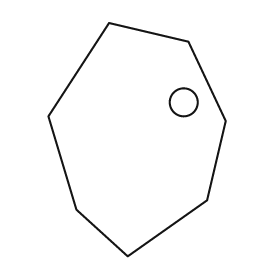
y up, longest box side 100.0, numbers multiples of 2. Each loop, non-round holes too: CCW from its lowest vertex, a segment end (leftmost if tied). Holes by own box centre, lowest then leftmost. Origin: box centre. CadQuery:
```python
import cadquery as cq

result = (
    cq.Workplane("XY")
    .moveTo(-4.0, -50.0)
    .lineTo(30.0, -26.0)
    .lineTo(38.0, 8.0)
    .lineTo(22.0, 42.0)
    .lineTo(-12.0, 50.0)
    .lineTo(-38.0, 10.0)
    .lineTo(-26.0, -30.0)
    .close()
    .moveTo(20.0, 16.0)
    .circle(6.0)
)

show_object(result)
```